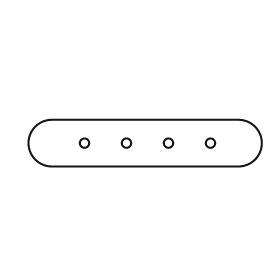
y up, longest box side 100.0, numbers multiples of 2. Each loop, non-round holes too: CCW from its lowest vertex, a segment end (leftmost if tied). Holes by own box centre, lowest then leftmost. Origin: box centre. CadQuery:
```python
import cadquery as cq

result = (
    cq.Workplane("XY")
    .moveTo(-40.0, -10.0)
    .lineTo(40.0, -10.0)
    .threePointArc((50.0, 0.0), (40.0, 10.0))
    .lineTo(-40.0, 10.0)
    .threePointArc((-50.0, 0.0), (-40.0, -10.0))
    .close()
    .moveTo(-26.0, 0.0)
    .circle(2.0)
    .moveTo(-8.0, 0.0)
    .circle(2.0)
    .moveTo(10.0, 0.0)
    .circle(2.0)
    .moveTo(28.0, 0.0)
    .circle(2.0)
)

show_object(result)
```